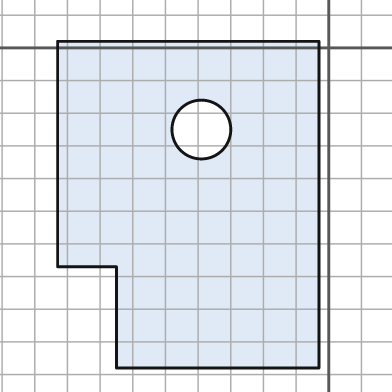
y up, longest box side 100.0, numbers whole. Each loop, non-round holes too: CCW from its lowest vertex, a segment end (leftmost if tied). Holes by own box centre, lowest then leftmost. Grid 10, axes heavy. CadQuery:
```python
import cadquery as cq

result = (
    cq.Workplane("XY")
    .moveTo(-65.0, -98.0)
    .lineTo(-3.0, -98.0)
    .lineTo(-3.0, 2.0)
    .lineTo(-83.0, 2.0)
    .lineTo(-83.0, -67.0)
    .lineTo(-65.0, -67.0)
    .close()
    .moveTo(-39.0, -25.0)
    .circle(9.0)
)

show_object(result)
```